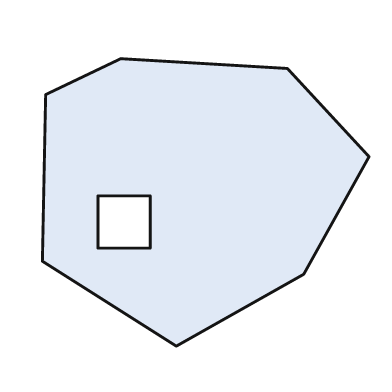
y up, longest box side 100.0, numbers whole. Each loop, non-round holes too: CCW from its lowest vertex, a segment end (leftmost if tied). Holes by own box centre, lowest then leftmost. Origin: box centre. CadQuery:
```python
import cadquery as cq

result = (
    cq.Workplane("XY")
    .moveTo(-9.0, -44.0)
    .lineTo(30.0, -22.0)
    .lineTo(50.0, 14.0)
    .lineTo(25.0, 41.0)
    .lineTo(-26.0, 44.0)
    .lineTo(-49.0, 33.0)
    .lineTo(-50.0, -18.0)
    .close()
    .moveTo(-33.0, -14.0)
    .lineTo(-17.0, -14.0)
    .lineTo(-17.0, 2.0)
    .lineTo(-33.0, 2.0)
    .close()
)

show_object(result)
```